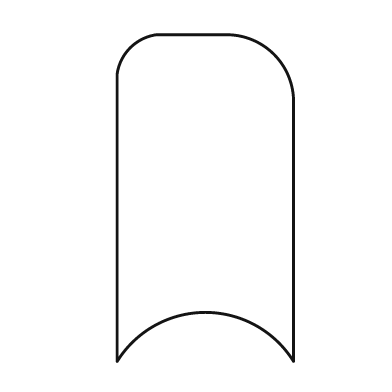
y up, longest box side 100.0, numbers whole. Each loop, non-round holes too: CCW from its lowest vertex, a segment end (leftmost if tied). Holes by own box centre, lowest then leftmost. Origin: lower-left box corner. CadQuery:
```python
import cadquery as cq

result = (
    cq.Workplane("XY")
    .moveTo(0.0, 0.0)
    .threePointArc((27.0, 15.0), (54.0, 0.0))
    .lineTo(54.0, 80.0)
    .threePointArc((48.0, 94.0), (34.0, 100.0))
    .lineTo(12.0, 100.0)
    .threePointArc((4.0, 96.0), (0.0, 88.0))
    .close()
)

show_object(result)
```